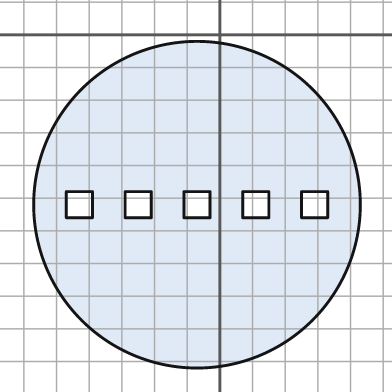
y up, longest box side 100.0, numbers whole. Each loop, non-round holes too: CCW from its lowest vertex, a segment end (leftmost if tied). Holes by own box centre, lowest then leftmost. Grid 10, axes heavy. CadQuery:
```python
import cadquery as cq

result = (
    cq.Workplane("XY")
    .moveTo(-7.0, -52.0)
    .circle(50.0)
    .moveTo(-47.0, -56.0)
    .lineTo(-39.0, -56.0)
    .lineTo(-39.0, -48.0)
    .lineTo(-47.0, -48.0)
    .close()
    .moveTo(-29.0, -56.0)
    .lineTo(-21.0, -56.0)
    .lineTo(-21.0, -48.0)
    .lineTo(-29.0, -48.0)
    .close()
    .moveTo(-11.0, -56.0)
    .lineTo(-3.0, -56.0)
    .lineTo(-3.0, -48.0)
    .lineTo(-11.0, -48.0)
    .close()
    .moveTo(7.0, -56.0)
    .lineTo(15.0, -56.0)
    .lineTo(15.0, -48.0)
    .lineTo(7.0, -48.0)
    .close()
    .moveTo(25.0, -56.0)
    .lineTo(33.0, -56.0)
    .lineTo(33.0, -48.0)
    .lineTo(25.0, -48.0)
    .close()
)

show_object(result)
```